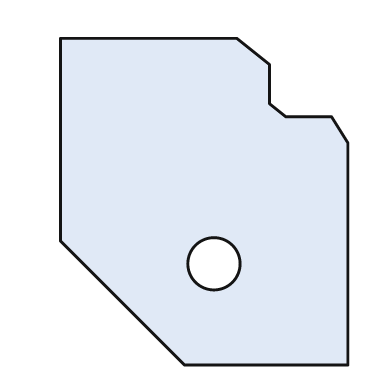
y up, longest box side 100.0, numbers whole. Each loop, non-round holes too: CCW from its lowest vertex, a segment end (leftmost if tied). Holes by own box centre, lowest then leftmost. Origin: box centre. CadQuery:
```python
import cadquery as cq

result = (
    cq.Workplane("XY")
    .moveTo(-6.0, -50.0)
    .lineTo(44.0, -50.0)
    .lineTo(44.0, 18.0)
    .lineTo(39.0, 26.0)
    .lineTo(25.0, 26.0)
    .lineTo(20.0, 30.0)
    .lineTo(20.0, 42.0)
    .lineTo(10.0, 50.0)
    .lineTo(-44.0, 50.0)
    .lineTo(-44.0, -12.0)
    .close()
    .moveTo(3.0, -19.0)
    .circle(8.0)
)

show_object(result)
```